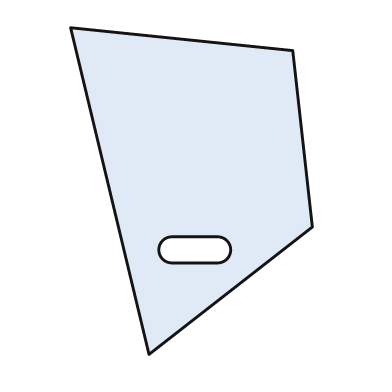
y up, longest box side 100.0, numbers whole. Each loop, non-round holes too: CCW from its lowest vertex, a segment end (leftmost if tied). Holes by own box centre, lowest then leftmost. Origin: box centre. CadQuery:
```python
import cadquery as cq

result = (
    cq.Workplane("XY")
    .moveTo(-13.0, -50.0)
    .lineTo(37.0, -11.0)
    .lineTo(31.0, 43.0)
    .lineTo(-37.0, 50.0)
    .close()
    .moveTo(-6.0, -22.0)
    .lineTo(8.0, -22.0)
    .threePointArc((12.0, -18.0), (8.0, -14.0))
    .lineTo(-6.0, -14.0)
    .threePointArc((-10.0, -18.0), (-6.0, -22.0))
    .close()
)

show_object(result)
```